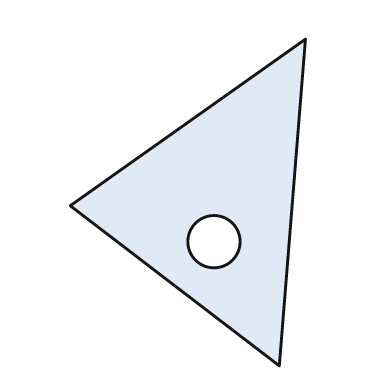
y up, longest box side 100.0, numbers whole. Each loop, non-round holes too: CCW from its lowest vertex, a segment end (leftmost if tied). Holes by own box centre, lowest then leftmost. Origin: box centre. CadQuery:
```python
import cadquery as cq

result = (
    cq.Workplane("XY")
    .moveTo(28.0, -50.0)
    .lineTo(36.0, 50.0)
    .lineTo(-36.0, -1.0)
    .close()
    .moveTo(8.0, -12.0)
    .circle(8.0)
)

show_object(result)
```